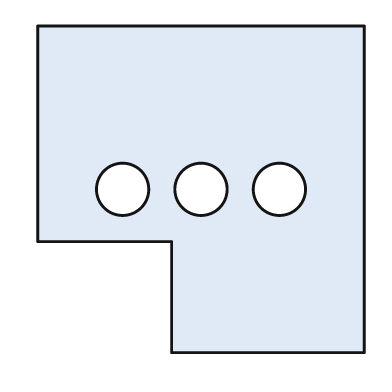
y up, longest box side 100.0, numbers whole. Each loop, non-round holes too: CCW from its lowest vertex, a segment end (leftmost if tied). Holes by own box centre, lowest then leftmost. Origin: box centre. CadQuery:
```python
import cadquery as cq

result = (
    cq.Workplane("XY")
    .moveTo(-9.0, -50.0)
    .lineTo(50.0, -50.0)
    .lineTo(50.0, 50.0)
    .lineTo(-50.0, 50.0)
    .lineTo(-50.0, -16.0)
    .lineTo(-9.0, -16.0)
    .close()
    .moveTo(-24.0, 0.0)
    .circle(8.0)
    .moveTo(0.0, 0.0)
    .circle(8.0)
    .moveTo(24.0, 0.0)
    .circle(8.0)
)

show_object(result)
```